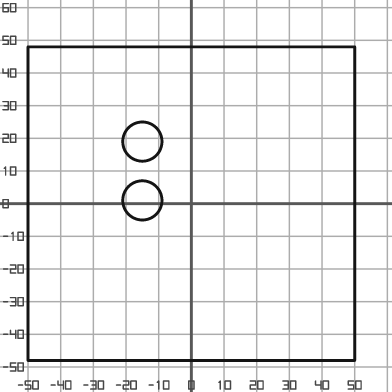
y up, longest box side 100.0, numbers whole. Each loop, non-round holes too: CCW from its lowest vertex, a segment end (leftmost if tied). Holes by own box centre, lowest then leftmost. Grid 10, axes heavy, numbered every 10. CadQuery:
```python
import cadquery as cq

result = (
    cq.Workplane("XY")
    .moveTo(-50.0, -48.0)
    .lineTo(50.0, -48.0)
    .lineTo(50.0, 48.0)
    .lineTo(-50.0, 48.0)
    .close()
    .moveTo(-15.0, 1.0)
    .circle(6.0)
    .moveTo(-15.0, 19.0)
    .circle(6.0)
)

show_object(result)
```